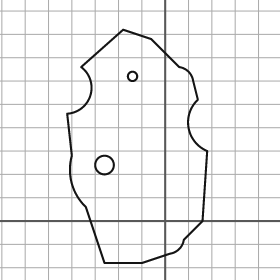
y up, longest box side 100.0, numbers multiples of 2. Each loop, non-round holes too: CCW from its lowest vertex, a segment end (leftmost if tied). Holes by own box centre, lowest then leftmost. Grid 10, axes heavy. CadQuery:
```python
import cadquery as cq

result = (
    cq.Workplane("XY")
    .moveTo(-26.0, -18.0)
    .lineTo(-10.0, -18.0)
    .lineTo(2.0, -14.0)
    .threePointArc((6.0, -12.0), (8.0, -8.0))
    .lineTo(16.0, 0.0)
    .lineTo(18.0, 30.0)
    .threePointArc((10.0, 40.0), (14.0, 52.0))
    .lineTo(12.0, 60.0)
    .threePointArc((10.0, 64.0), (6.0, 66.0))
    .lineTo(-6.0, 78.0)
    .lineTo(-18.0, 82.0)
    .lineTo(-36.0, 66.0)
    .threePointArc((-32.0, 54.0), (-42.0, 46.0))
    .lineTo(-40.0, 28.0)
    .threePointArc((-40.0, 16.0), (-34.0, 6.0))
    .close()
    .moveTo(-26.0, 24.0)
    .circle(4.0)
    .moveTo(-14.0, 62.0)
    .circle(2.0)
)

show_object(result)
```